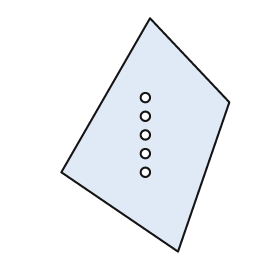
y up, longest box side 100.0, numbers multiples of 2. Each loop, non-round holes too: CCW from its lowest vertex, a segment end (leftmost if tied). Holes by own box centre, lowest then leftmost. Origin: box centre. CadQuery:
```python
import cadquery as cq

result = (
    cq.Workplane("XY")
    .moveTo(14.0, -50.0)
    .lineTo(36.0, 14.0)
    .lineTo(2.0, 50.0)
    .lineTo(-36.0, -16.0)
    .close()
    .moveTo(0.0, -16.0)
    .circle(2.0)
    .moveTo(0.0, -8.0)
    .circle(2.0)
    .moveTo(0.0, 0.0)
    .circle(2.0)
    .moveTo(0.0, 8.0)
    .circle(2.0)
    .moveTo(0.0, 16.0)
    .circle(2.0)
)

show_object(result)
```